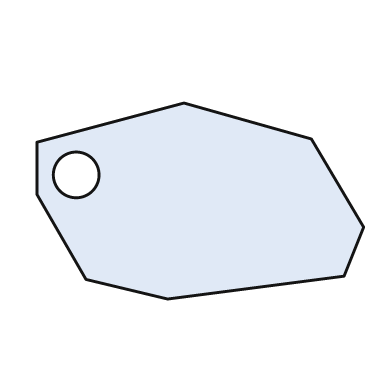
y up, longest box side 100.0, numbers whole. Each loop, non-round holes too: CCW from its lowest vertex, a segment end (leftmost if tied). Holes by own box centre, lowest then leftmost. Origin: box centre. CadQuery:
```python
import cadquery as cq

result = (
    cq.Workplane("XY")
    .moveTo(-10.0, -30.0)
    .lineTo(44.0, -23.0)
    .lineTo(50.0, -8.0)
    .lineTo(34.0, 19.0)
    .lineTo(-5.0, 30.0)
    .lineTo(-50.0, 18.0)
    .lineTo(-50.0, 2.0)
    .lineTo(-35.0, -24.0)
    .close()
    .moveTo(-38.0, 8.0)
    .circle(7.0)
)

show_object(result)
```